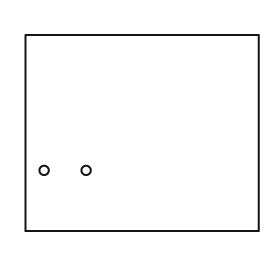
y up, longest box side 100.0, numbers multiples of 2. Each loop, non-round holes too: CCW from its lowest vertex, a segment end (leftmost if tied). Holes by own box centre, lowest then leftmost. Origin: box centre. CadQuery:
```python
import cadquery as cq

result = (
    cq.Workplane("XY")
    .moveTo(-50.0, -42.0)
    .lineTo(50.0, -42.0)
    .lineTo(50.0, 42.0)
    .lineTo(-50.0, 42.0)
    .close()
    .moveTo(-42.0, -16.0)
    .circle(2.0)
    .moveTo(-24.0, -16.0)
    .circle(2.0)
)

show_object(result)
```